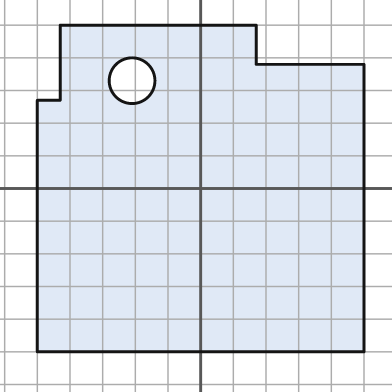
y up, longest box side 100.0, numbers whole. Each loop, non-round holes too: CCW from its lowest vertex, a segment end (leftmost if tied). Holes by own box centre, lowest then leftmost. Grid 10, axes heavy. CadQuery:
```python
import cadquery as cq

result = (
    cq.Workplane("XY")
    .moveTo(-50.0, -50.0)
    .lineTo(50.0, -50.0)
    .lineTo(50.0, 38.0)
    .lineTo(17.0, 38.0)
    .lineTo(17.0, 50.0)
    .lineTo(-43.0, 50.0)
    .lineTo(-43.0, 27.0)
    .lineTo(-50.0, 27.0)
    .close()
    .moveTo(-21.0, 33.0)
    .circle(7.0)
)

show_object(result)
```